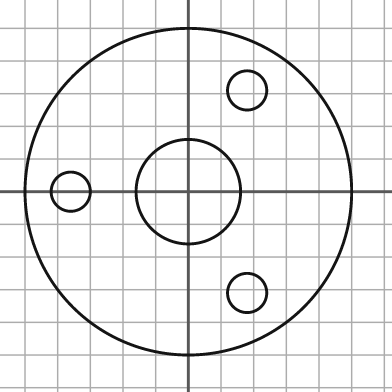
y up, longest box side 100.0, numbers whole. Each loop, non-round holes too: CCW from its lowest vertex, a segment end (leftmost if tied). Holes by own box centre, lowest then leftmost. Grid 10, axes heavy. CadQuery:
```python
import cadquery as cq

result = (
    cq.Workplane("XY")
    .moveTo(0.0, 0.0)
    .circle(50.0)
    .moveTo(18.0, -31.0)
    .circle(6.0)
    .moveTo(-36.0, 0.0)
    .circle(6.0)
    .moveTo(0.0, 0.0)
    .circle(16.0)
    .moveTo(18.0, 31.0)
    .circle(6.0)
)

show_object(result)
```